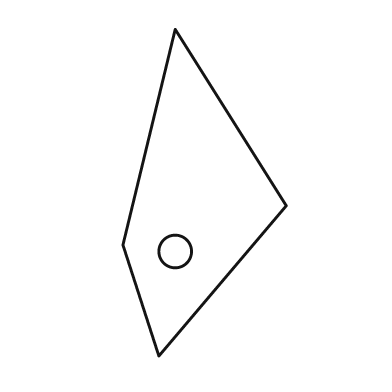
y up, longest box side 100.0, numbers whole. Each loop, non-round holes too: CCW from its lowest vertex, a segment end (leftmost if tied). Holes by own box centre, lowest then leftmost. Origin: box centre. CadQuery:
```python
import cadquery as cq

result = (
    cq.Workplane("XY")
    .moveTo(-14.0, -50.0)
    .lineTo(25.0, -4.0)
    .lineTo(-9.0, 50.0)
    .lineTo(-25.0, -16.0)
    .close()
    .moveTo(-9.0, -18.0)
    .circle(5.0)
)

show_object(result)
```